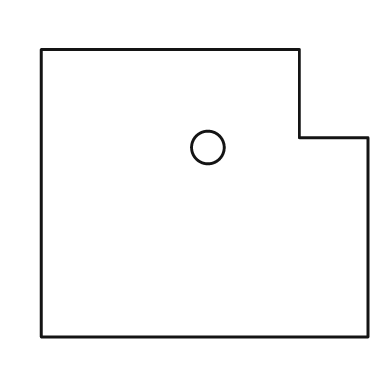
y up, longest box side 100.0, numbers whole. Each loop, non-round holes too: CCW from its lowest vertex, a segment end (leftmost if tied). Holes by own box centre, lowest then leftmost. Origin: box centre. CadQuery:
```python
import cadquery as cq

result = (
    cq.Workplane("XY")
    .moveTo(-50.0, -44.0)
    .lineTo(50.0, -44.0)
    .lineTo(50.0, 17.0)
    .lineTo(29.0, 17.0)
    .lineTo(29.0, 44.0)
    .lineTo(-50.0, 44.0)
    .close()
    .moveTo(1.0, 14.0)
    .circle(5.0)
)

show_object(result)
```